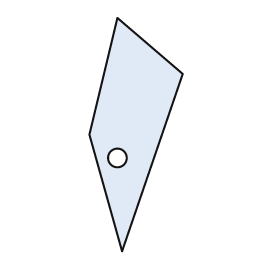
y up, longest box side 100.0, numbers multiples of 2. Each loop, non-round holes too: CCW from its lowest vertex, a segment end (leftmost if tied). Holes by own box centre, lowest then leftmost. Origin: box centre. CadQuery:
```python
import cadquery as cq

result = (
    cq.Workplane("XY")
    .moveTo(-6.0, -50.0)
    .lineTo(20.0, 26.0)
    .lineTo(-8.0, 50.0)
    .lineTo(-20.0, 0.0)
    .close()
    .moveTo(-8.0, -10.0)
    .circle(4.0)
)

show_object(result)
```